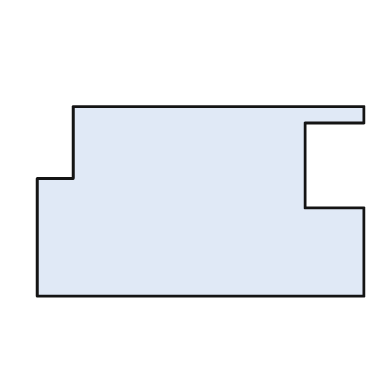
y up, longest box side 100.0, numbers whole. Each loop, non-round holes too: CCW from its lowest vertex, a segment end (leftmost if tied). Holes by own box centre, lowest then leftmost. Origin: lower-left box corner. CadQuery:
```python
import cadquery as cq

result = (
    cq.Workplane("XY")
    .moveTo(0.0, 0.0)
    .lineTo(100.0, 0.0)
    .lineTo(100.0, 27.0)
    .lineTo(82.0, 27.0)
    .lineTo(82.0, 53.0)
    .lineTo(100.0, 53.0)
    .lineTo(100.0, 58.0)
    .lineTo(11.0, 58.0)
    .lineTo(11.0, 36.0)
    .lineTo(0.0, 36.0)
    .close()
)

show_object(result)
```